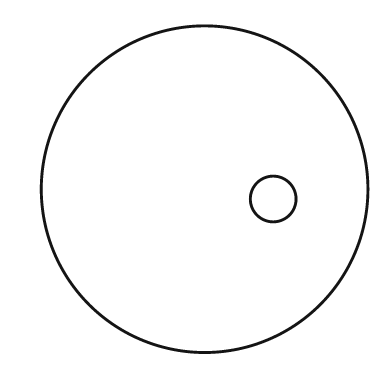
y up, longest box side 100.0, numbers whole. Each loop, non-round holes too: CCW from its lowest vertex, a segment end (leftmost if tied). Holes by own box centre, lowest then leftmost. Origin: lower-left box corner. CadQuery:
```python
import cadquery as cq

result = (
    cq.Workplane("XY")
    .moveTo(50.0, 50.0)
    .circle(50.0)
    .moveTo(71.0, 47.0)
    .circle(7.0)
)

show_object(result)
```